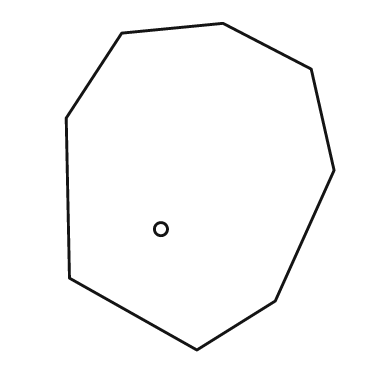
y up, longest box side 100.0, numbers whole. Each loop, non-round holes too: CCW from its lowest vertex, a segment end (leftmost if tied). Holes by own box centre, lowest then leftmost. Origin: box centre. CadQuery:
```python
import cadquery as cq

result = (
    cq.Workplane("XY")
    .moveTo(-1.0, -50.0)
    .lineTo(23.0, -35.0)
    .lineTo(41.0, 5.0)
    .lineTo(34.0, 36.0)
    .lineTo(7.0, 50.0)
    .lineTo(-24.0, 47.0)
    .lineTo(-41.0, 21.0)
    .lineTo(-40.0, -28.0)
    .close()
    .moveTo(-12.0, -13.0)
    .circle(2.0)
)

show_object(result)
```